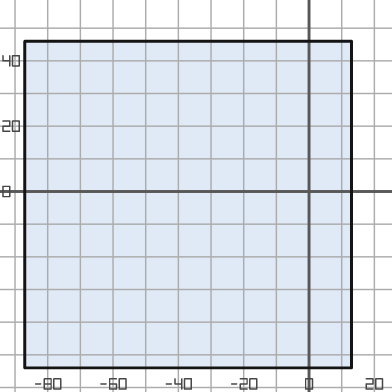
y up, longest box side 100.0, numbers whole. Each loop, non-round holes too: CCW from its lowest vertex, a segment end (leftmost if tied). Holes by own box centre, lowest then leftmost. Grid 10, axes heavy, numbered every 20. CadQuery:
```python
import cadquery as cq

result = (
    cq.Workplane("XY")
    .moveTo(-87.0, -54.0)
    .lineTo(13.0, -54.0)
    .lineTo(13.0, 46.0)
    .lineTo(-87.0, 46.0)
    .close()
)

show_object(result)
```